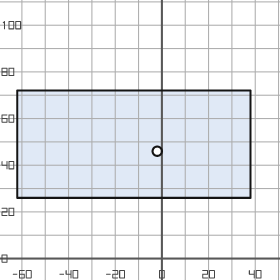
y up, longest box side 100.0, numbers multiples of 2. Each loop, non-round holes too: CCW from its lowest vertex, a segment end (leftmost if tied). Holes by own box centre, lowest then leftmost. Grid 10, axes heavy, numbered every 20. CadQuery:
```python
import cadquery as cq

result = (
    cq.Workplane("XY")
    .moveTo(-62.0, 26.0)
    .lineTo(38.0, 26.0)
    .lineTo(38.0, 72.0)
    .lineTo(-62.0, 72.0)
    .close()
    .moveTo(-2.0, 46.0)
    .circle(2.0)
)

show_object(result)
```